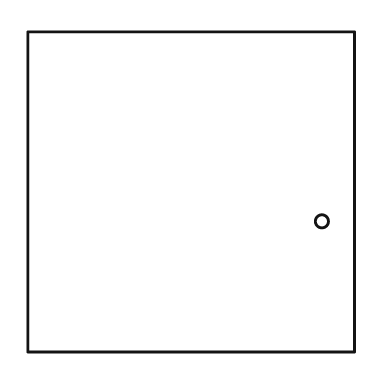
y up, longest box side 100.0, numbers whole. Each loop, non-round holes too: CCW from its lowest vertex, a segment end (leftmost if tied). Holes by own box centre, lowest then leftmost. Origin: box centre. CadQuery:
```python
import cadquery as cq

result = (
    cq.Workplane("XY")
    .moveTo(-50.0, -49.0)
    .lineTo(50.0, -49.0)
    .lineTo(50.0, 49.0)
    .lineTo(-50.0, 49.0)
    .close()
    .moveTo(40.0, -9.0)
    .circle(2.0)
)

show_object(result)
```